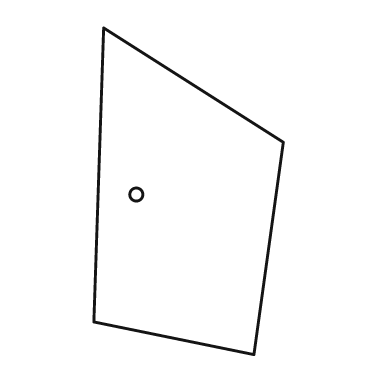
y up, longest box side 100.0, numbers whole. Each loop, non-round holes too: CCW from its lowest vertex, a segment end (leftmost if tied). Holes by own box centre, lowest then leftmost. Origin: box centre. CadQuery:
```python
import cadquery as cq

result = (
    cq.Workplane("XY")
    .moveTo(20.0, -50.0)
    .lineTo(29.0, 15.0)
    .lineTo(-26.0, 50.0)
    .lineTo(-29.0, -40.0)
    .close()
    .moveTo(-16.0, -1.0)
    .circle(2.0)
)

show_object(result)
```